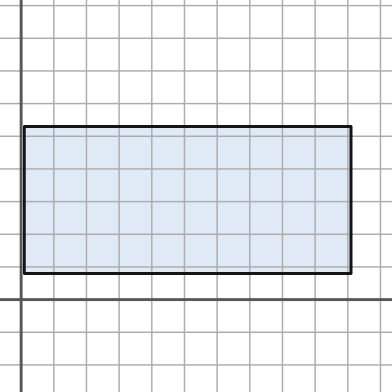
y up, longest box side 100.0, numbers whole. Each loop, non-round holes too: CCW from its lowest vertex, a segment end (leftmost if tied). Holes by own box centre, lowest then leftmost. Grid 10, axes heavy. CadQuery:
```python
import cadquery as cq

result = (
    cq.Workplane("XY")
    .moveTo(1.0, 8.0)
    .lineTo(101.0, 8.0)
    .lineTo(101.0, 53.0)
    .lineTo(1.0, 53.0)
    .close()
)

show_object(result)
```